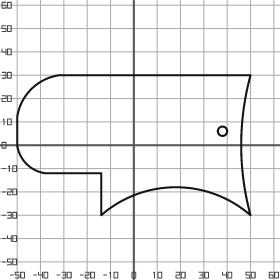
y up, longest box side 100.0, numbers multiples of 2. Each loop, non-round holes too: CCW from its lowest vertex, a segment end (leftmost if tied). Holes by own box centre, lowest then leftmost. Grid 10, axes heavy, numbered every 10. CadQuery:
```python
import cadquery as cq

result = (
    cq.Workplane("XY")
    .moveTo(-14.0, -30.0)
    .threePointArc((18.0, -18.0), (50.0, -30.0))
    .threePointArc((46.0, 0.0), (50.0, 30.0))
    .lineTo(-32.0, 30.0)
    .threePointArc((-44.0, 24.0), (-50.0, 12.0))
    .lineTo(-50.0, 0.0)
    .threePointArc((-46.0, -8.0), (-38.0, -12.0))
    .lineTo(-14.0, -12.0)
    .close()
    .moveTo(38.0, 6.0)
    .circle(2.0)
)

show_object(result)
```